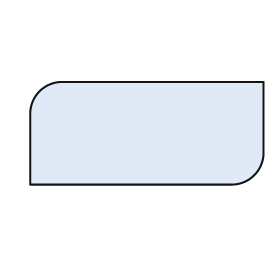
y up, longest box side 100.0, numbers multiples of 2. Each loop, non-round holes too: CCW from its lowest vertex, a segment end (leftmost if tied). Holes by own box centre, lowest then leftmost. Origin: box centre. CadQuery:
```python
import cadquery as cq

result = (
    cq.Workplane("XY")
    .moveTo(-50.0, -22.0)
    .lineTo(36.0, -22.0)
    .threePointArc((46.0, -18.0), (50.0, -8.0))
    .lineTo(50.0, 22.0)
    .lineTo(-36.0, 22.0)
    .threePointArc((-46.0, 18.0), (-50.0, 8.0))
    .close()
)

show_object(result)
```